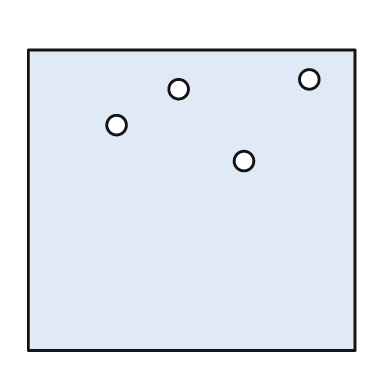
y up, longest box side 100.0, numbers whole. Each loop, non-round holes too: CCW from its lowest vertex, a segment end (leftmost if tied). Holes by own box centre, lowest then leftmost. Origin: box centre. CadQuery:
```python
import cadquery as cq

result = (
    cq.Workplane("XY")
    .moveTo(-50.0, -46.0)
    .lineTo(50.0, -46.0)
    .lineTo(50.0, 46.0)
    .lineTo(-50.0, 46.0)
    .close()
    .moveTo(16.0, 12.0)
    .circle(3.0)
    .moveTo(-23.0, 23.0)
    .circle(3.0)
    .moveTo(-4.0, 34.0)
    .circle(3.0)
    .moveTo(36.0, 37.0)
    .circle(3.0)
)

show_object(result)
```